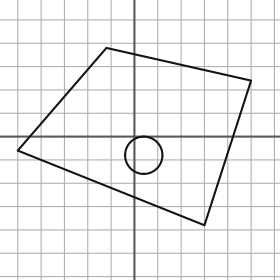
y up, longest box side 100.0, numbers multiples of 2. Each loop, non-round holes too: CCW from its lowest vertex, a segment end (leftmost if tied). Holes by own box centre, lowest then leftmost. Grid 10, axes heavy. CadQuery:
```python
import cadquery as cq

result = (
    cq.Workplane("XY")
    .moveTo(30.0, -38.0)
    .lineTo(50.0, 24.0)
    .lineTo(-12.0, 38.0)
    .lineTo(-50.0, -6.0)
    .close()
    .moveTo(4.0, -8.0)
    .circle(8.0)
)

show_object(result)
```